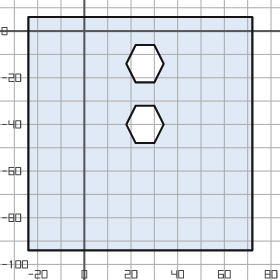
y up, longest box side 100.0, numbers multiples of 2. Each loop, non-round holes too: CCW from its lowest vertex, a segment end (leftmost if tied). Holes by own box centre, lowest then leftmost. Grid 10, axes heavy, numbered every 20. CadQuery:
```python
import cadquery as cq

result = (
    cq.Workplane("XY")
    .moveTo(-24.0, -94.0)
    .lineTo(72.0, -94.0)
    .lineTo(72.0, 6.0)
    .lineTo(-24.0, 6.0)
    .close()
    .moveTo(22.0, -48.0)
    .lineTo(30.0, -48.0)
    .lineTo(34.0, -40.0)
    .lineTo(30.0, -32.0)
    .lineTo(22.0, -32.0)
    .lineTo(18.0, -40.0)
    .close()
    .moveTo(22.0, -22.0)
    .lineTo(30.0, -22.0)
    .lineTo(34.0, -14.0)
    .lineTo(30.0, -6.0)
    .lineTo(22.0, -6.0)
    .lineTo(18.0, -14.0)
    .close()
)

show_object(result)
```